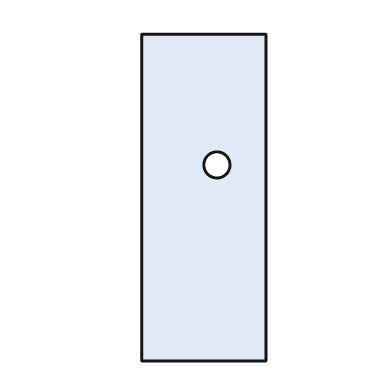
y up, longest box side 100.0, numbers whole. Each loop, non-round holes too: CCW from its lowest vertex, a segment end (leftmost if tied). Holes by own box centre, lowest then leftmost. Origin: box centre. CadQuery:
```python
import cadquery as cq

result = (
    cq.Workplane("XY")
    .moveTo(-19.0, -50.0)
    .lineTo(19.0, -50.0)
    .lineTo(19.0, 50.0)
    .lineTo(-19.0, 50.0)
    .close()
    .moveTo(4.0, 10.0)
    .circle(4.0)
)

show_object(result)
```